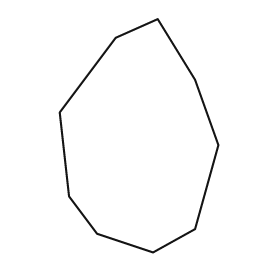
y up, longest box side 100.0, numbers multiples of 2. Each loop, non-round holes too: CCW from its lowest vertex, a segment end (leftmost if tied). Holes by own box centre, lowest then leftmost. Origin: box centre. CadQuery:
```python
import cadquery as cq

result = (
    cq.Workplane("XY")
    .moveTo(6.0, -50.0)
    .lineTo(24.0, -40.0)
    .lineTo(34.0, -4.0)
    .lineTo(24.0, 24.0)
    .lineTo(8.0, 50.0)
    .lineTo(-10.0, 42.0)
    .lineTo(-34.0, 10.0)
    .lineTo(-30.0, -26.0)
    .lineTo(-18.0, -42.0)
    .close()
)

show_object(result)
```